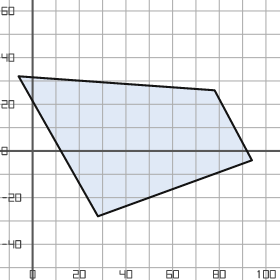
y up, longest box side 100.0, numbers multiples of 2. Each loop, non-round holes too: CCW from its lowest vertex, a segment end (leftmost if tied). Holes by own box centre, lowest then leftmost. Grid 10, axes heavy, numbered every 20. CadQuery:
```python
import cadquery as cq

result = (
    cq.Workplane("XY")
    .moveTo(28.0, -28.0)
    .lineTo(94.0, -4.0)
    .lineTo(78.0, 26.0)
    .lineTo(-6.0, 32.0)
    .close()
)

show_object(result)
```